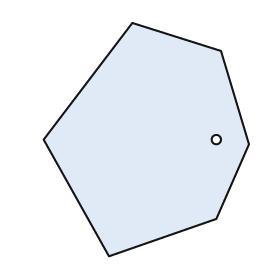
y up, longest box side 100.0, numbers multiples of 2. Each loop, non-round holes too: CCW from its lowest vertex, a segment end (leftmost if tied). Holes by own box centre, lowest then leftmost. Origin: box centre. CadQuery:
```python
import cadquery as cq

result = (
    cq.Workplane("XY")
    .moveTo(-16.0, -50.0)
    .lineTo(30.0, -34.0)
    .lineTo(44.0, -2.0)
    .lineTo(32.0, 38.0)
    .lineTo(-6.0, 50.0)
    .lineTo(-44.0, 0.0)
    .close()
    .moveTo(30.0, 0.0)
    .circle(2.0)
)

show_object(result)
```